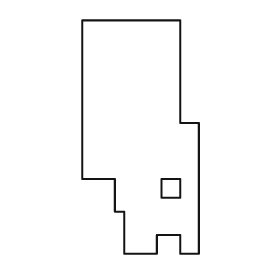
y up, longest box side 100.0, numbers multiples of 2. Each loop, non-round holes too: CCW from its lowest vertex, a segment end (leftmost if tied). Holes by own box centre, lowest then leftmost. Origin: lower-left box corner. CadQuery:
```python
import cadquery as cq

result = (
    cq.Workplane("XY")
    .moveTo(18.0, 0.0)
    .lineTo(32.0, 0.0)
    .lineTo(32.0, 8.0)
    .lineTo(42.0, 8.0)
    .lineTo(42.0, 0.0)
    .lineTo(50.0, 0.0)
    .lineTo(50.0, 56.0)
    .lineTo(42.0, 56.0)
    .lineTo(42.0, 100.0)
    .lineTo(0.0, 100.0)
    .lineTo(0.0, 32.0)
    .lineTo(14.0, 32.0)
    .lineTo(14.0, 18.0)
    .lineTo(18.0, 18.0)
    .close()
    .moveTo(34.0, 24.0)
    .lineTo(42.0, 24.0)
    .lineTo(42.0, 32.0)
    .lineTo(34.0, 32.0)
    .close()
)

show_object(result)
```